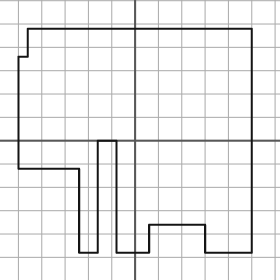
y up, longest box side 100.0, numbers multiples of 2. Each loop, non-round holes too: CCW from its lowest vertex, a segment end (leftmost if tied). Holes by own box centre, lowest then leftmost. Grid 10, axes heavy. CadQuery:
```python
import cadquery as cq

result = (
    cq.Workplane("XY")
    .moveTo(-24.0, -48.0)
    .lineTo(-16.0, -48.0)
    .lineTo(-16.0, 0.0)
    .lineTo(-8.0, 0.0)
    .lineTo(-8.0, -48.0)
    .lineTo(6.0, -48.0)
    .lineTo(6.0, -36.0)
    .lineTo(30.0, -36.0)
    .lineTo(30.0, -48.0)
    .lineTo(50.0, -48.0)
    .lineTo(50.0, 48.0)
    .lineTo(-46.0, 48.0)
    .lineTo(-46.0, 36.0)
    .lineTo(-50.0, 36.0)
    .lineTo(-50.0, -12.0)
    .lineTo(-24.0, -12.0)
    .close()
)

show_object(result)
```